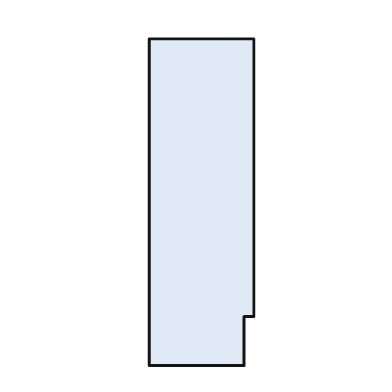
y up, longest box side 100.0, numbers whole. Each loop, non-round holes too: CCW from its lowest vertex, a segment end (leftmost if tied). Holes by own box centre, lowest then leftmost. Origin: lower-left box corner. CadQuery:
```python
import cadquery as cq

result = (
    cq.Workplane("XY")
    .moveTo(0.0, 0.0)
    .lineTo(29.0, 0.0)
    .lineTo(29.0, 15.0)
    .lineTo(32.0, 15.0)
    .lineTo(32.0, 100.0)
    .lineTo(0.0, 100.0)
    .close()
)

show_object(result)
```